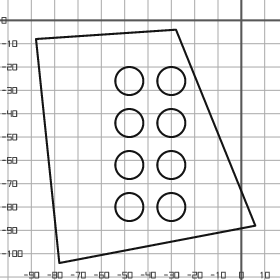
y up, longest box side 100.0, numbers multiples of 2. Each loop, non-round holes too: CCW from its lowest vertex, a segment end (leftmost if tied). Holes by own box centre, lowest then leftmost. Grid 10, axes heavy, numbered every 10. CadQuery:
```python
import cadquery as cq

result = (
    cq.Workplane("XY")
    .moveTo(-78.0, -104.0)
    .lineTo(6.0, -88.0)
    .lineTo(-28.0, -4.0)
    .lineTo(-88.0, -8.0)
    .close()
    .moveTo(-48.0, -80.0)
    .circle(6.0)
    .moveTo(-30.0, -80.0)
    .circle(6.0)
    .moveTo(-48.0, -62.0)
    .circle(6.0)
    .moveTo(-30.0, -62.0)
    .circle(6.0)
    .moveTo(-48.0, -44.0)
    .circle(6.0)
    .moveTo(-30.0, -44.0)
    .circle(6.0)
    .moveTo(-48.0, -26.0)
    .circle(6.0)
    .moveTo(-30.0, -26.0)
    .circle(6.0)
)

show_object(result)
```